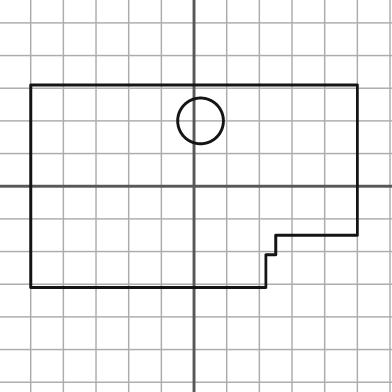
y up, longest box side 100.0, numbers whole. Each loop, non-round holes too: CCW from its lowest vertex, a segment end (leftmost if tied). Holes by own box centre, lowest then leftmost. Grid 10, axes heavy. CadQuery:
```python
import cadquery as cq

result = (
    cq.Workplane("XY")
    .moveTo(-50.0, -31.0)
    .lineTo(22.0, -31.0)
    .lineTo(22.0, -21.0)
    .lineTo(25.0, -21.0)
    .lineTo(25.0, -15.0)
    .lineTo(50.0, -15.0)
    .lineTo(50.0, 31.0)
    .lineTo(-50.0, 31.0)
    .close()
    .moveTo(2.0, 20.0)
    .circle(7.0)
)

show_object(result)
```